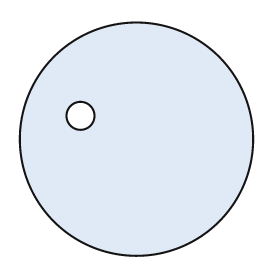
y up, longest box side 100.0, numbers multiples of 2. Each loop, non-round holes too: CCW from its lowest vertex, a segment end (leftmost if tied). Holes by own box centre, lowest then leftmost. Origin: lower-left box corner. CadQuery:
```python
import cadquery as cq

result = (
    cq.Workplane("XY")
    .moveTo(50.0, 50.0)
    .circle(50.0)
    .moveTo(26.0, 60.0)
    .circle(6.0)
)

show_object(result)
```